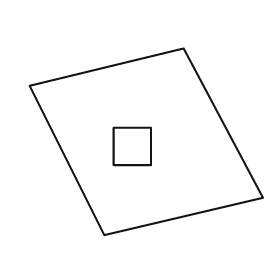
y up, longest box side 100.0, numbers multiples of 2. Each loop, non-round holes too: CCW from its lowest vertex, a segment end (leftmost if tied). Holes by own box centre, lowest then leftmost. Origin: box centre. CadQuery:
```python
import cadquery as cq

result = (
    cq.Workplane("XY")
    .moveTo(-18.0, -40.0)
    .lineTo(50.0, -24.0)
    .lineTo(16.0, 40.0)
    .lineTo(-50.0, 24.0)
    .close()
    .moveTo(-14.0, -10.0)
    .lineTo(2.0, -10.0)
    .lineTo(2.0, 6.0)
    .lineTo(-14.0, 6.0)
    .close()
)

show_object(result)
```